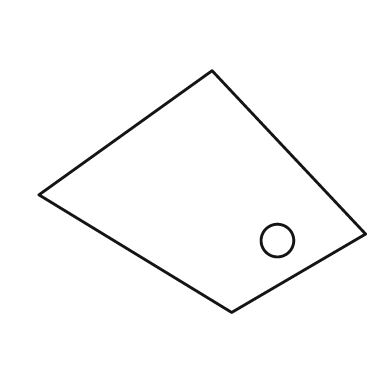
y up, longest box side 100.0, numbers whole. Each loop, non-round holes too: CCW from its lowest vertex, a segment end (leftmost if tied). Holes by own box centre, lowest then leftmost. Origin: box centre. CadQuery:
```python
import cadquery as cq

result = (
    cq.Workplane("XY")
    .moveTo(9.0, -37.0)
    .lineTo(50.0, -13.0)
    .lineTo(3.0, 37.0)
    .lineTo(-50.0, -1.0)
    .close()
    .moveTo(23.0, -15.0)
    .circle(5.0)
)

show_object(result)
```